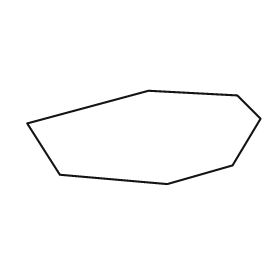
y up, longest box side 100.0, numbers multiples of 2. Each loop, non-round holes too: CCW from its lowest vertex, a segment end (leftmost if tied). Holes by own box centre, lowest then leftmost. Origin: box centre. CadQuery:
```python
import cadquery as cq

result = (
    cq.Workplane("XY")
    .moveTo(10.0, -20.0)
    .lineTo(38.0, -12.0)
    .lineTo(50.0, 8.0)
    .lineTo(40.0, 18.0)
    .lineTo(2.0, 20.0)
    .lineTo(-50.0, 6.0)
    .lineTo(-36.0, -16.0)
    .close()
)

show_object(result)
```